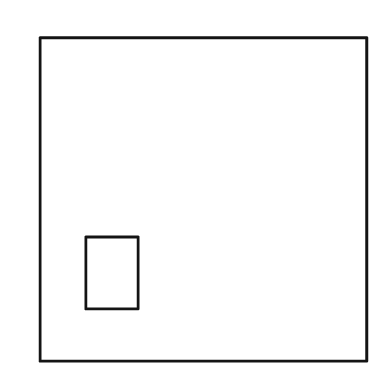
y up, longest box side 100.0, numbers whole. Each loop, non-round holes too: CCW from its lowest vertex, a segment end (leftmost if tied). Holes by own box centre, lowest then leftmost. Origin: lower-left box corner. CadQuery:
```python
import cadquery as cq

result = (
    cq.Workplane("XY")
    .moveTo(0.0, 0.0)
    .lineTo(100.0, 0.0)
    .lineTo(100.0, 99.0)
    .lineTo(0.0, 99.0)
    .close()
    .moveTo(14.0, 16.0)
    .lineTo(30.0, 16.0)
    .lineTo(30.0, 38.0)
    .lineTo(14.0, 38.0)
    .close()
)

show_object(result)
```